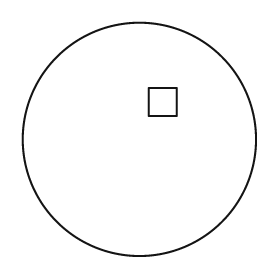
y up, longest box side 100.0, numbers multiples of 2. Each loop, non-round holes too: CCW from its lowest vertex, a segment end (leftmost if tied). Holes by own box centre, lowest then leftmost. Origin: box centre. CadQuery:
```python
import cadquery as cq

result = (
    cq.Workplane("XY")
    .moveTo(0.0, 0.0)
    .circle(50.0)
    .moveTo(4.0, 10.0)
    .lineTo(16.0, 10.0)
    .lineTo(16.0, 22.0)
    .lineTo(4.0, 22.0)
    .close()
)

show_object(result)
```